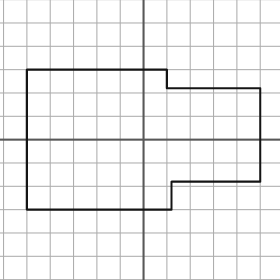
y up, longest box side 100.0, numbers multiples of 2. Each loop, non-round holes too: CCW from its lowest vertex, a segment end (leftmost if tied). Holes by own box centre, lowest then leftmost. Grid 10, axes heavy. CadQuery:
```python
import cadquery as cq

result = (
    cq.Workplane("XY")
    .moveTo(-50.0, -30.0)
    .lineTo(12.0, -30.0)
    .lineTo(12.0, -18.0)
    .lineTo(50.0, -18.0)
    .lineTo(50.0, 22.0)
    .lineTo(10.0, 22.0)
    .lineTo(10.0, 30.0)
    .lineTo(-50.0, 30.0)
    .close()
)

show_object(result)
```